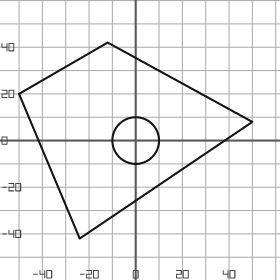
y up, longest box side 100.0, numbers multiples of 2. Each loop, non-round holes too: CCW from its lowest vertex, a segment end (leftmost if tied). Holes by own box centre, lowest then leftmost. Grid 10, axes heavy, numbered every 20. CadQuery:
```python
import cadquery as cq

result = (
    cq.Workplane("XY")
    .moveTo(-24.0, -42.0)
    .lineTo(50.0, 8.0)
    .lineTo(-12.0, 42.0)
    .lineTo(-50.0, 20.0)
    .close()
    .moveTo(0.0, 0.0)
    .circle(10.0)
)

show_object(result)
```